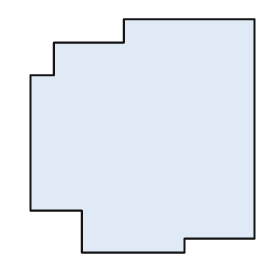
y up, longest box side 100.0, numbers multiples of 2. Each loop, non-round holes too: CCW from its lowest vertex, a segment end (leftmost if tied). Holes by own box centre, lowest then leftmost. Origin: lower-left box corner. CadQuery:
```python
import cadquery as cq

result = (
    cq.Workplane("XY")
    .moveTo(22.0, 0.0)
    .lineTo(66.0, 0.0)
    .lineTo(66.0, 6.0)
    .lineTo(96.0, 6.0)
    .lineTo(96.0, 100.0)
    .lineTo(40.0, 100.0)
    .lineTo(40.0, 90.0)
    .lineTo(10.0, 90.0)
    .lineTo(10.0, 76.0)
    .lineTo(0.0, 76.0)
    .lineTo(0.0, 18.0)
    .lineTo(22.0, 18.0)
    .close()
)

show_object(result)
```